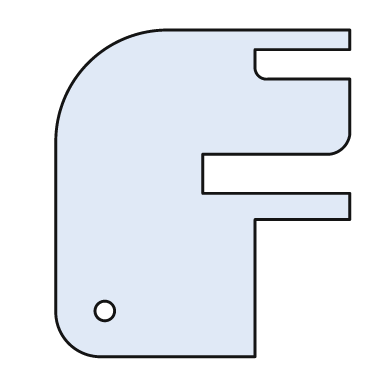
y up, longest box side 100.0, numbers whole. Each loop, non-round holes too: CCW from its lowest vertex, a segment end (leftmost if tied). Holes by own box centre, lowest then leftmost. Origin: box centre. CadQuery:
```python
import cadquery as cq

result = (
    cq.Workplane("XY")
    .moveTo(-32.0, -50.0)
    .lineTo(16.0, -50.0)
    .lineTo(16.0, -8.0)
    .lineTo(45.0, -8.0)
    .lineTo(45.0, 0.0)
    .lineTo(0.0, 0.0)
    .lineTo(0.0, 12.0)
    .lineTo(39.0, 12.0)
    .threePointArc((43.0, 14.0), (45.0, 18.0))
    .lineTo(45.0, 35.0)
    .lineTo(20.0, 35.0)
    .threePointArc((17.0, 36.0), (16.0, 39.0))
    .lineTo(16.0, 44.0)
    .lineTo(45.0, 44.0)
    .lineTo(45.0, 50.0)
    .lineTo(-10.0, 50.0)
    .threePointArc((-35.0, 40.0), (-45.0, 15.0))
    .lineTo(-45.0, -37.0)
    .threePointArc((-41.0, -46.0), (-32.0, -50.0))
    .close()
    .moveTo(-30.0, -36.0)
    .circle(3.0)
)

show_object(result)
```